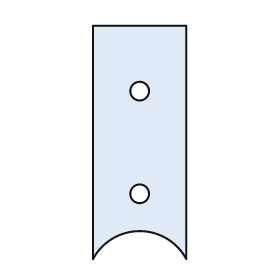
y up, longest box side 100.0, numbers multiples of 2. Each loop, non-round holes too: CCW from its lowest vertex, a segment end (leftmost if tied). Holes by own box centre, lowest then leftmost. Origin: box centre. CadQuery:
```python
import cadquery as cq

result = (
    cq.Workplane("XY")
    .moveTo(-20.0, -50.0)
    .threePointArc((0.0, -38.0), (20.0, -50.0))
    .lineTo(20.0, 50.0)
    .lineTo(-20.0, 50.0)
    .close()
    .moveTo(0.0, -22.0)
    .circle(4.0)
    .moveTo(0.0, 22.0)
    .circle(4.0)
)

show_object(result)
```